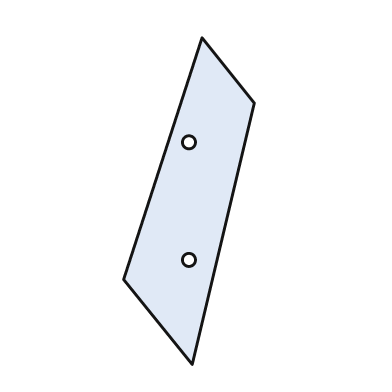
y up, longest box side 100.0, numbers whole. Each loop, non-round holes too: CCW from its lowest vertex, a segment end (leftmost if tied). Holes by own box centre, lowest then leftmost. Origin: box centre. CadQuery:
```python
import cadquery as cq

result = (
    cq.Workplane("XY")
    .moveTo(1.0, -50.0)
    .lineTo(20.0, 30.0)
    .lineTo(4.0, 50.0)
    .lineTo(-20.0, -24.0)
    .close()
    .moveTo(0.0, -18.0)
    .circle(2.0)
    .moveTo(0.0, 18.0)
    .circle(2.0)
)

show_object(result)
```